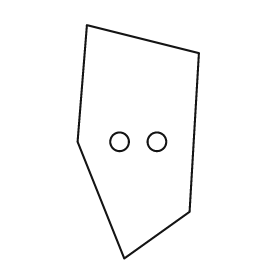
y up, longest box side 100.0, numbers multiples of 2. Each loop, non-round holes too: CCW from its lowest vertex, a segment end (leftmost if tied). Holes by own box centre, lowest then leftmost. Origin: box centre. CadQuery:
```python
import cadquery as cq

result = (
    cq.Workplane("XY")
    .moveTo(-6.0, -50.0)
    .lineTo(22.0, -30.0)
    .lineTo(26.0, 38.0)
    .lineTo(-22.0, 50.0)
    .lineTo(-26.0, 0.0)
    .close()
    .moveTo(-8.0, 0.0)
    .circle(4.0)
    .moveTo(8.0, 0.0)
    .circle(4.0)
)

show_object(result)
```